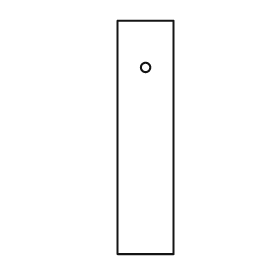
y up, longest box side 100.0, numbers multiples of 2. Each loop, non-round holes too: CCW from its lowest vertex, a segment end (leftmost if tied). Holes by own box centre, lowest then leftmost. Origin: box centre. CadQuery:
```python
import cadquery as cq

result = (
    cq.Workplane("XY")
    .moveTo(-12.0, -50.0)
    .lineTo(12.0, -50.0)
    .lineTo(12.0, 50.0)
    .lineTo(-12.0, 50.0)
    .close()
    .moveTo(0.0, 30.0)
    .circle(2.0)
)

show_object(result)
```